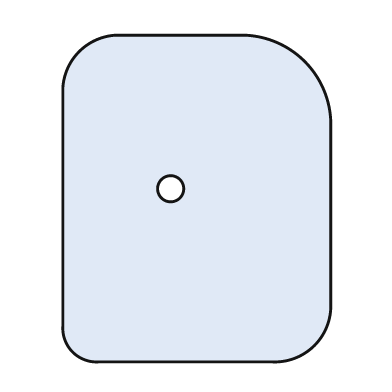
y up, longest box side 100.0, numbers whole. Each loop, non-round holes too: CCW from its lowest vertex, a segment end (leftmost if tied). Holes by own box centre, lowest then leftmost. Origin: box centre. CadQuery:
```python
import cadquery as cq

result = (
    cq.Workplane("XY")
    .moveTo(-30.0, -50.0)
    .lineTo(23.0, -50.0)
    .threePointArc((36.0, -45.0), (41.0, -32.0))
    .lineTo(41.0, 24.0)
    .threePointArc((33.0, 42.0), (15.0, 50.0))
    .lineTo(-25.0, 50.0)
    .threePointArc((-36.0, 45.0), (-41.0, 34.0))
    .lineTo(-41.0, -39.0)
    .threePointArc((-38.0, -47.0), (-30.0, -50.0))
    .close()
    .moveTo(-8.0, 3.0)
    .circle(4.0)
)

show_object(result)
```